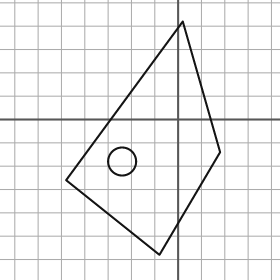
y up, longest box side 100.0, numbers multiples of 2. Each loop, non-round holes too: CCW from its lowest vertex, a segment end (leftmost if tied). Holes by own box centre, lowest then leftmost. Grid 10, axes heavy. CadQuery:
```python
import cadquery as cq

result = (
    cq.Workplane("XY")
    .moveTo(-8.0, -58.0)
    .lineTo(18.0, -14.0)
    .lineTo(2.0, 42.0)
    .lineTo(-48.0, -26.0)
    .close()
    .moveTo(-24.0, -18.0)
    .circle(6.0)
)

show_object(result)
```